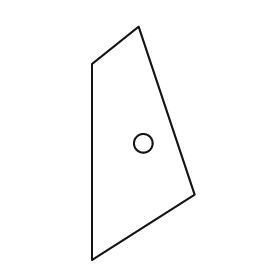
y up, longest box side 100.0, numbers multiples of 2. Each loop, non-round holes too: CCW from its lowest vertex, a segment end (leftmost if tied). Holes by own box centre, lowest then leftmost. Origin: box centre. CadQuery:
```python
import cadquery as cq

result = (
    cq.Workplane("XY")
    .moveTo(-22.0, -50.0)
    .lineTo(22.0, -22.0)
    .lineTo(-2.0, 50.0)
    .lineTo(-22.0, 34.0)
    .close()
    .moveTo(0.0, 0.0)
    .circle(4.0)
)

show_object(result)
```